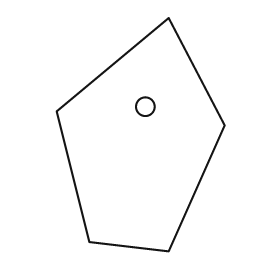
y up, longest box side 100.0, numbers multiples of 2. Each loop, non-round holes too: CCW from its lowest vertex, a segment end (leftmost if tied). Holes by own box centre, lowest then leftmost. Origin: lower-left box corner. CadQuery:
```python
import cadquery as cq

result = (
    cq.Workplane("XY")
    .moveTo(48.0, 0.0)
    .lineTo(72.0, 54.0)
    .lineTo(48.0, 100.0)
    .lineTo(0.0, 60.0)
    .lineTo(14.0, 4.0)
    .close()
    .moveTo(38.0, 62.0)
    .circle(4.0)
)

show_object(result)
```